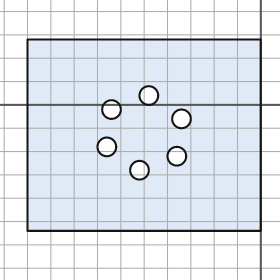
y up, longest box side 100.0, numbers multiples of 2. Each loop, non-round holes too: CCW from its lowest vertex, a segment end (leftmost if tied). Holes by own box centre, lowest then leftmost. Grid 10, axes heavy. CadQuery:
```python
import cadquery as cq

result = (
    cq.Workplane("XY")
    .moveTo(-100.0, -54.0)
    .lineTo(0.0, -54.0)
    .lineTo(0.0, 28.0)
    .lineTo(-100.0, 28.0)
    .close()
    .moveTo(-52.0, -28.0)
    .circle(4.0)
    .moveTo(-36.0, -22.0)
    .circle(4.0)
    .moveTo(-66.0, -18.0)
    .circle(4.0)
    .moveTo(-34.0, -6.0)
    .circle(4.0)
    .moveTo(-64.0, -2.0)
    .circle(4.0)
    .moveTo(-48.0, 4.0)
    .circle(4.0)
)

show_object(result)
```